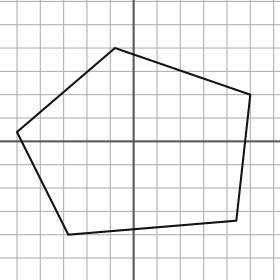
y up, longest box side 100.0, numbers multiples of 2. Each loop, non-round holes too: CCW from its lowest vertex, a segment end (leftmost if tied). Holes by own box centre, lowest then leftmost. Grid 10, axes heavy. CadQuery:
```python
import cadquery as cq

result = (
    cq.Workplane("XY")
    .moveTo(-28.0, -40.0)
    .lineTo(44.0, -34.0)
    .lineTo(50.0, 20.0)
    .lineTo(-8.0, 40.0)
    .lineTo(-50.0, 4.0)
    .close()
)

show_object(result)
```